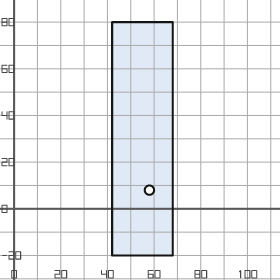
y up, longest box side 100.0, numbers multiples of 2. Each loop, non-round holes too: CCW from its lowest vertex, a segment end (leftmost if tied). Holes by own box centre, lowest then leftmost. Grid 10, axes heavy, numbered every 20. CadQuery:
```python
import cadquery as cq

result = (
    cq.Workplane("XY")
    .moveTo(42.0, -20.0)
    .lineTo(68.0, -20.0)
    .lineTo(68.0, 80.0)
    .lineTo(42.0, 80.0)
    .close()
    .moveTo(58.0, 8.0)
    .circle(2.0)
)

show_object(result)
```